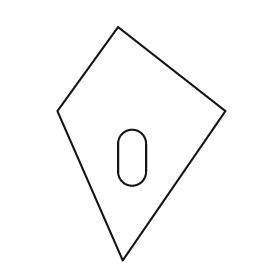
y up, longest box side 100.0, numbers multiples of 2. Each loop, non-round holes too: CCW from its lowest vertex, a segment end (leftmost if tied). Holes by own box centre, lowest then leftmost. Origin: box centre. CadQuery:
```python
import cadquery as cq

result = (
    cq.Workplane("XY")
    .moveTo(-8.0, -50.0)
    .lineTo(36.0, 14.0)
    .lineTo(-10.0, 50.0)
    .lineTo(-36.0, 14.0)
    .close()
    .moveTo(-10.0, -12.0)
    .threePointArc((-4.0, -18.0), (2.0, -12.0))
    .lineTo(2.0, 0.0)
    .threePointArc((-4.0, 6.0), (-10.0, 0.0))
    .close()
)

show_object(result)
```